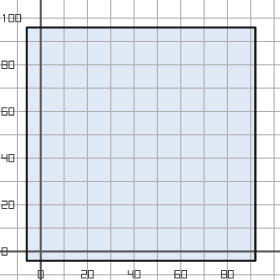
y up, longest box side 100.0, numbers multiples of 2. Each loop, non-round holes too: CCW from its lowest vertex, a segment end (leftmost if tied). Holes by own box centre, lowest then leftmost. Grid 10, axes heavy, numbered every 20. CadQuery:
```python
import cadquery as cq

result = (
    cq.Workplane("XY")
    .moveTo(-6.0, -4.0)
    .lineTo(92.0, -4.0)
    .lineTo(92.0, 96.0)
    .lineTo(-6.0, 96.0)
    .close()
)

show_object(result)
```